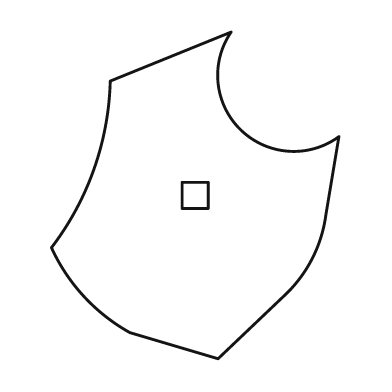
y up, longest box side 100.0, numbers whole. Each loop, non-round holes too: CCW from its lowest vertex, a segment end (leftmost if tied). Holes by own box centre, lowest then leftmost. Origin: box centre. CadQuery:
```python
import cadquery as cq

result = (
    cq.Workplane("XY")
    .moveTo(7.0, -50.0)
    .lineTo(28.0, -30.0)
    .threePointArc((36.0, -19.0), (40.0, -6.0))
    .lineTo(44.0, 18.0)
    .threePointArc((14.0, 20.0), (11.0, 50.0))
    .lineTo(-26.0, 35.0)
    .threePointArc((-31.0, 8.0), (-44.0, -16.0))
    .threePointArc((-34.0, -31.0), (-20.0, -42.0))
    .close()
    .moveTo(-4.0, -4.0)
    .lineTo(4.0, -4.0)
    .lineTo(4.0, 4.0)
    .lineTo(-4.0, 4.0)
    .close()
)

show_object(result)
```